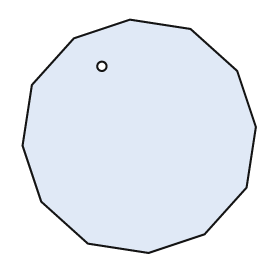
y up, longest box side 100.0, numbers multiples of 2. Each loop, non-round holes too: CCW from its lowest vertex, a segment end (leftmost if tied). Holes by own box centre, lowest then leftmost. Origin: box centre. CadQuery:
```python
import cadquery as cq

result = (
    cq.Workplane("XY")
    .moveTo(4.0, -50.0)
    .lineTo(28.0, -42.0)
    .lineTo(46.0, -22.0)
    .lineTo(50.0, 4.0)
    .lineTo(42.0, 28.0)
    .lineTo(22.0, 46.0)
    .lineTo(-4.0, 50.0)
    .lineTo(-28.0, 42.0)
    .lineTo(-46.0, 22.0)
    .lineTo(-50.0, -4.0)
    .lineTo(-42.0, -28.0)
    .lineTo(-22.0, -46.0)
    .close()
    .moveTo(-16.0, 30.0)
    .circle(2.0)
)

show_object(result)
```